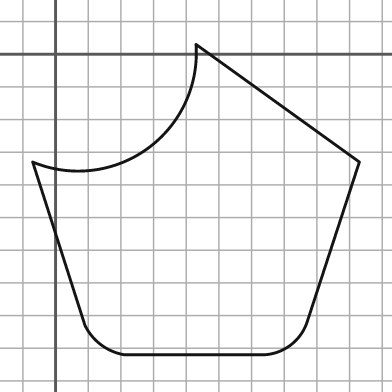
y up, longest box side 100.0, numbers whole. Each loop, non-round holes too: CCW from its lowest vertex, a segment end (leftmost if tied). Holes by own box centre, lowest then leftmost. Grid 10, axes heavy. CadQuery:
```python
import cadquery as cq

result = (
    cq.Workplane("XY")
    .moveTo(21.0, -92.0)
    .lineTo(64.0, -92.0)
    .threePointArc((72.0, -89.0), (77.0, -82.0))
    .lineTo(93.0, -33.0)
    .lineTo(43.0, 3.0)
    .threePointArc((28.0, -29.0), (-7.0, -33.0))
    .lineTo(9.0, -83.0)
    .threePointArc((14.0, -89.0), (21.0, -92.0))
    .close()
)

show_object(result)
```